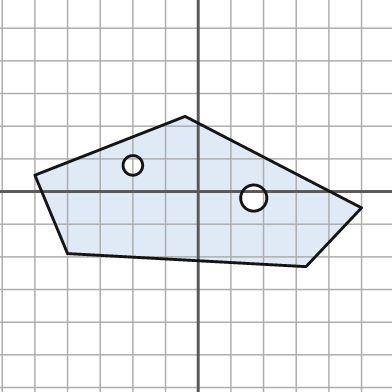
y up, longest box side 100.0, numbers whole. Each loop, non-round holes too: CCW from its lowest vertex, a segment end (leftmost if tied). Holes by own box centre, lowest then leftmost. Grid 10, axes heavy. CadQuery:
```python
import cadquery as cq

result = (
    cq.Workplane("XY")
    .moveTo(33.0, -23.0)
    .lineTo(50.0, -5.0)
    .lineTo(-4.0, 23.0)
    .lineTo(-50.0, 5.0)
    .lineTo(-40.0, -19.0)
    .close()
    .moveTo(17.0, -2.0)
    .circle(4.0)
    .moveTo(-20.0, 8.0)
    .circle(3.0)
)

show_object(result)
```